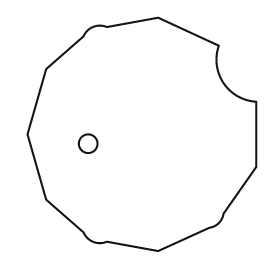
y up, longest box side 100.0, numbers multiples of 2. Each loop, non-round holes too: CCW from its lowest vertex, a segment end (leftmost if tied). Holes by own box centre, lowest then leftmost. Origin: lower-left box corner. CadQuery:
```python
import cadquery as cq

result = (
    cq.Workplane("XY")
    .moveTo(56.0, 0.0)
    .lineTo(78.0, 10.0)
    .threePointArc((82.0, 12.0), (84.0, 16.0))
    .lineTo(98.0, 36.0)
    .lineTo(98.0, 64.0)
    .threePointArc((84.0, 72.0), (82.0, 88.0))
    .lineTo(56.0, 100.0)
    .lineTo(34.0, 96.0)
    .threePointArc((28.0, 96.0), (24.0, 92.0))
    .lineTo(8.0, 78.0)
    .lineTo(0.0, 50.0)
    .lineTo(8.0, 22.0)
    .lineTo(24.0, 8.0)
    .threePointArc((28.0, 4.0), (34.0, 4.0))
    .close()
    .moveTo(26.0, 46.0)
    .circle(4.0)
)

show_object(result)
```